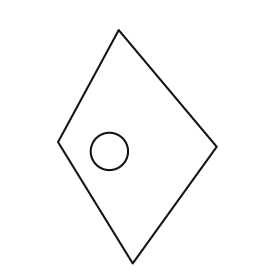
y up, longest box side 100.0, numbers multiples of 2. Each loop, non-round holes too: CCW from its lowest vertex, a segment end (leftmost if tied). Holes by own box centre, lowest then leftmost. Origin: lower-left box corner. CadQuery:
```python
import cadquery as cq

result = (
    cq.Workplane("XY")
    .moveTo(32.0, 0.0)
    .lineTo(68.0, 50.0)
    .lineTo(26.0, 100.0)
    .lineTo(0.0, 52.0)
    .close()
    .moveTo(22.0, 48.0)
    .circle(8.0)
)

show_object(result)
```